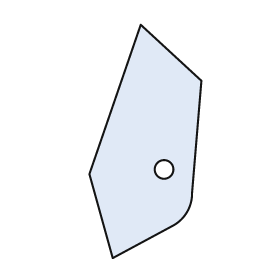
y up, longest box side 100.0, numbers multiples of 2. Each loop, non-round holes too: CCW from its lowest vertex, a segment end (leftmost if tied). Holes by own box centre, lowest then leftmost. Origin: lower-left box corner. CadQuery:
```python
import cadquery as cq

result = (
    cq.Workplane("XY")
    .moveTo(10.0, 0.0)
    .lineTo(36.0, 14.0)
    .threePointArc((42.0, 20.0), (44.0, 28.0))
    .lineTo(48.0, 76.0)
    .lineTo(22.0, 100.0)
    .lineTo(0.0, 36.0)
    .close()
    .moveTo(32.0, 38.0)
    .circle(4.0)
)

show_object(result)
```